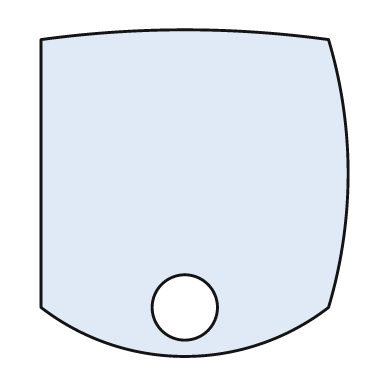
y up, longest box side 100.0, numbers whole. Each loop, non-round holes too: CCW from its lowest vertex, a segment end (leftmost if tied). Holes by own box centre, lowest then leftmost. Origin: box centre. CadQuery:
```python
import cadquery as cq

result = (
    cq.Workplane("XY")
    .moveTo(-47.0, -35.0)
    .threePointArc((-3.0, -50.0), (41.0, -35.0))
    .threePointArc((47.0, 6.0), (41.0, 47.0))
    .threePointArc((-3.0, 50.0), (-47.0, 47.0))
    .close()
    .moveTo(-3.0, -35.0)
    .circle(10.0)
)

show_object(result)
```